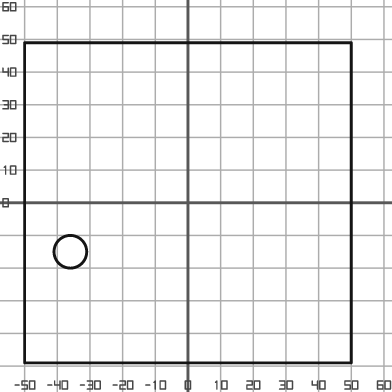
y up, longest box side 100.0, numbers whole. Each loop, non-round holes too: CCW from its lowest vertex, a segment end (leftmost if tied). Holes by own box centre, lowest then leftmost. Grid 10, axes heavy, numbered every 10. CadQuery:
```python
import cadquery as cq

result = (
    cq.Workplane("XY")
    .moveTo(-50.0, -49.0)
    .lineTo(50.0, -49.0)
    .lineTo(50.0, 49.0)
    .lineTo(-50.0, 49.0)
    .close()
    .moveTo(-36.0, -15.0)
    .circle(5.0)
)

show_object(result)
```